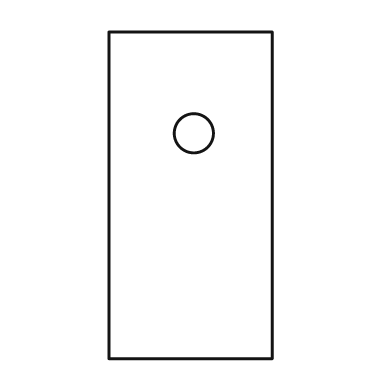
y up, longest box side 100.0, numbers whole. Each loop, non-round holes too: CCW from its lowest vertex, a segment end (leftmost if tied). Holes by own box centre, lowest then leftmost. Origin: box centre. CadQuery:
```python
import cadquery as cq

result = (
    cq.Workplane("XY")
    .moveTo(-25.0, -50.0)
    .lineTo(25.0, -50.0)
    .lineTo(25.0, 50.0)
    .lineTo(-25.0, 50.0)
    .close()
    .moveTo(1.0, 19.0)
    .circle(6.0)
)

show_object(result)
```